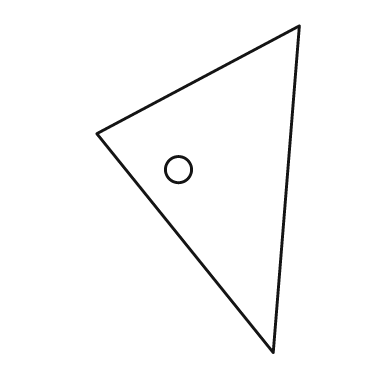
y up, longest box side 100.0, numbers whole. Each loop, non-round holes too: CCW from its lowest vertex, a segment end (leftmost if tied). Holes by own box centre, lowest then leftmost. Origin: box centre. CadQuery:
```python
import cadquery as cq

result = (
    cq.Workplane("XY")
    .moveTo(23.0, -50.0)
    .lineTo(31.0, 50.0)
    .lineTo(-31.0, 17.0)
    .close()
    .moveTo(-6.0, 6.0)
    .circle(4.0)
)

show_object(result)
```